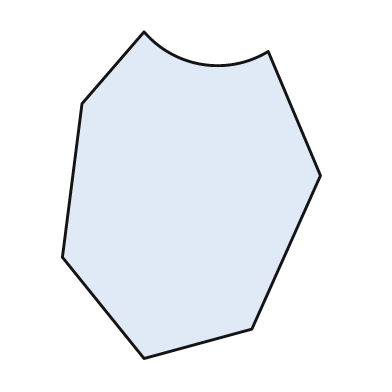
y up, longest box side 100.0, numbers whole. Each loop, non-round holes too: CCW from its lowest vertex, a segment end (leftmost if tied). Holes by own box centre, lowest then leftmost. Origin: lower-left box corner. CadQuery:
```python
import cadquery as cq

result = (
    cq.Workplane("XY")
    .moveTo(25.0, 0.0)
    .lineTo(58.0, 9.0)
    .lineTo(79.0, 56.0)
    .lineTo(63.0, 94.0)
    .threePointArc((43.0, 90.0), (25.0, 100.0))
    .lineTo(6.0, 78.0)
    .lineTo(0.0, 31.0)
    .close()
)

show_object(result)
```